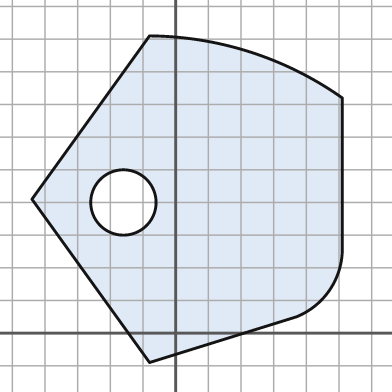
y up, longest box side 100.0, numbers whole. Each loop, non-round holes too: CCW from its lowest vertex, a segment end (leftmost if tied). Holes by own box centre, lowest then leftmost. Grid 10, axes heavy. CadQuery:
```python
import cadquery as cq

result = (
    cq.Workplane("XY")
    .moveTo(-8.0, -9.0)
    .lineTo(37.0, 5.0)
    .threePointArc((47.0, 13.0), (51.0, 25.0))
    .lineTo(51.0, 72.0)
    .threePointArc((23.0, 86.0), (-8.0, 91.0))
    .lineTo(-44.0, 41.0)
    .close()
    .moveTo(-16.0, 40.0)
    .circle(10.0)
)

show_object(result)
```